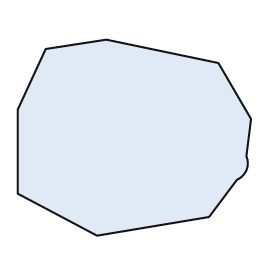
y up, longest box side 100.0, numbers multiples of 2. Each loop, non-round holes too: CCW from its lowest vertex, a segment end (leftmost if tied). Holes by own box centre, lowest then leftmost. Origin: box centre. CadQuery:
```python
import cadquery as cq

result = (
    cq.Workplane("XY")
    .moveTo(-16.0, -42.0)
    .lineTo(32.0, -34.0)
    .lineTo(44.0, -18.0)
    .threePointArc((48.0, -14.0), (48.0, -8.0))
    .lineTo(50.0, 8.0)
    .lineTo(36.0, 32.0)
    .lineTo(-12.0, 42.0)
    .lineTo(-38.0, 38.0)
    .lineTo(-50.0, 12.0)
    .lineTo(-50.0, -24.0)
    .close()
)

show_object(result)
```